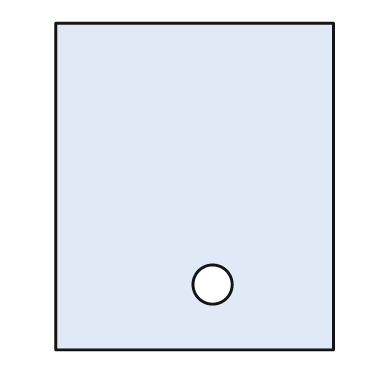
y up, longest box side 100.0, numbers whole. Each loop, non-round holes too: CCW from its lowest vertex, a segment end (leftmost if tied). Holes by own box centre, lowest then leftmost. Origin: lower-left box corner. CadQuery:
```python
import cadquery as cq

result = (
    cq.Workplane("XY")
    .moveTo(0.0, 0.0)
    .lineTo(85.0, 0.0)
    .lineTo(85.0, 100.0)
    .lineTo(0.0, 100.0)
    .close()
    .moveTo(48.0, 20.0)
    .circle(6.0)
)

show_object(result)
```